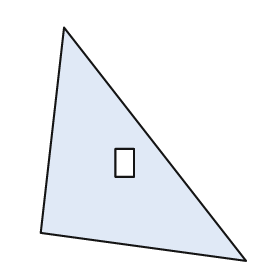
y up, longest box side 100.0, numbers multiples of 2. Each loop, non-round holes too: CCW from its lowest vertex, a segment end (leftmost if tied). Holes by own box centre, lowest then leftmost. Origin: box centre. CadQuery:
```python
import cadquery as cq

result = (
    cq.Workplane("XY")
    .moveTo(44.0, -50.0)
    .lineTo(-34.0, 50.0)
    .lineTo(-44.0, -38.0)
    .close()
    .moveTo(-12.0, -14.0)
    .lineTo(-4.0, -14.0)
    .lineTo(-4.0, -2.0)
    .lineTo(-12.0, -2.0)
    .close()
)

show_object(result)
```